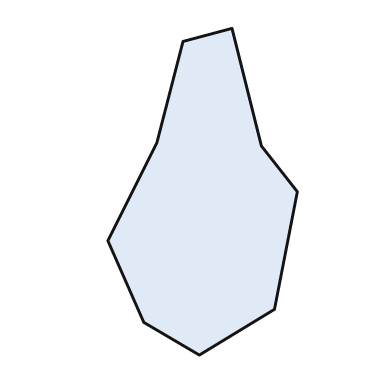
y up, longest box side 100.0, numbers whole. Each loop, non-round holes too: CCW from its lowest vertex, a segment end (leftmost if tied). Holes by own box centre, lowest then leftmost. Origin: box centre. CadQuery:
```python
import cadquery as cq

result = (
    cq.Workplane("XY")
    .moveTo(-1.0, -50.0)
    .lineTo(22.0, -36.0)
    .lineTo(29.0, 0.0)
    .lineTo(18.0, 14.0)
    .lineTo(9.0, 50.0)
    .lineTo(-6.0, 46.0)
    .lineTo(-14.0, 15.0)
    .lineTo(-29.0, -15.0)
    .lineTo(-18.0, -40.0)
    .close()
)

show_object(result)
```